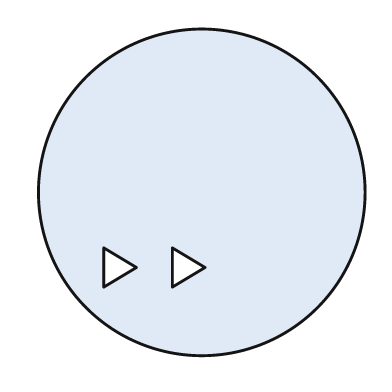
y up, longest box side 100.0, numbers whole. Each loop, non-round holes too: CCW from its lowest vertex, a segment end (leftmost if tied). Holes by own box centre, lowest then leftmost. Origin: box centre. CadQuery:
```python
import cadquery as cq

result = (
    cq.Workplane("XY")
    .moveTo(0.0, 0.0)
    .circle(50.0)
    .moveTo(-30.0, -29.0)
    .lineTo(-20.0, -23.0)
    .lineTo(-30.0, -17.0)
    .close()
    .moveTo(-9.0, -29.0)
    .lineTo(1.0, -23.0)
    .lineTo(-9.0, -17.0)
    .close()
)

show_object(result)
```